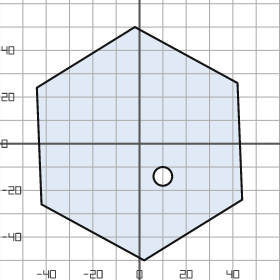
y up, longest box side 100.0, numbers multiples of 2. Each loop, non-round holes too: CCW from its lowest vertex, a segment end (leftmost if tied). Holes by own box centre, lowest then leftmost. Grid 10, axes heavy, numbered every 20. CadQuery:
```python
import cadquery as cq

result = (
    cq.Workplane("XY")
    .moveTo(2.0, -50.0)
    .lineTo(44.0, -24.0)
    .lineTo(42.0, 26.0)
    .lineTo(-2.0, 50.0)
    .lineTo(-44.0, 24.0)
    .lineTo(-42.0, -26.0)
    .close()
    .moveTo(10.0, -14.0)
    .circle(4.0)
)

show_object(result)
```